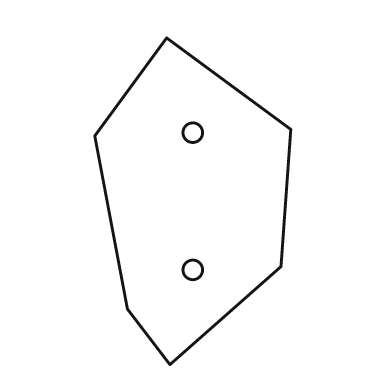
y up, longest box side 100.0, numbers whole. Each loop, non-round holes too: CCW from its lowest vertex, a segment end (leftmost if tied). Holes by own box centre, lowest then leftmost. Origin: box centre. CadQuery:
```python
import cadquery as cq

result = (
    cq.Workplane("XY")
    .moveTo(-7.0, -50.0)
    .lineTo(27.0, -20.0)
    .lineTo(30.0, 22.0)
    .lineTo(-8.0, 50.0)
    .lineTo(-30.0, 20.0)
    .lineTo(-20.0, -33.0)
    .close()
    .moveTo(0.0, -21.0)
    .circle(3.0)
    .moveTo(0.0, 21.0)
    .circle(3.0)
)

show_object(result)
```